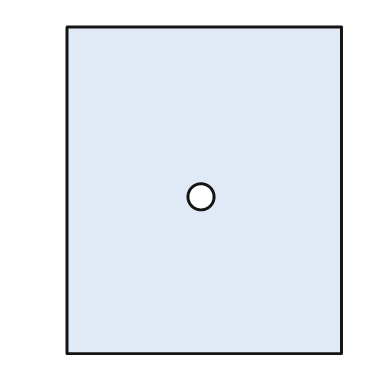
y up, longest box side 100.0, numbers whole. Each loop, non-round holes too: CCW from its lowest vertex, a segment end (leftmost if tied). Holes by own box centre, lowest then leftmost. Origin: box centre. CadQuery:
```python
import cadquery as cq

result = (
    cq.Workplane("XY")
    .moveTo(-42.0, -50.0)
    .lineTo(42.0, -50.0)
    .lineTo(42.0, 50.0)
    .lineTo(-42.0, 50.0)
    .close()
    .moveTo(-1.0, -2.0)
    .circle(4.0)
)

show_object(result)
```